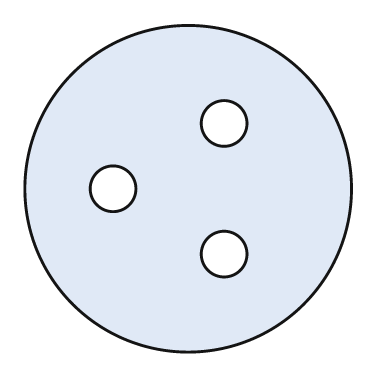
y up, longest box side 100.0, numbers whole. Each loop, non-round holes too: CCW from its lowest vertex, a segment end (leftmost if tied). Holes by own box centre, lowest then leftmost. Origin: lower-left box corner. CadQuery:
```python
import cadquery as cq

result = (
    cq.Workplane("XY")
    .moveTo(50.0, 50.0)
    .circle(50.0)
    .moveTo(61.0, 30.0)
    .circle(7.0)
    .moveTo(27.0, 50.0)
    .circle(7.0)
    .moveTo(61.0, 70.0)
    .circle(7.0)
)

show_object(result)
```